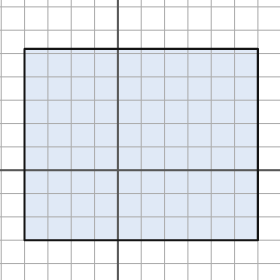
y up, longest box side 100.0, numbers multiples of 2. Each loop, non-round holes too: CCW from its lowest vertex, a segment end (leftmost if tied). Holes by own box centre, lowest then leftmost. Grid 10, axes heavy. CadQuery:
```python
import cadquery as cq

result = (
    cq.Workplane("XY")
    .moveTo(-40.0, -30.0)
    .lineTo(60.0, -30.0)
    .lineTo(60.0, 52.0)
    .lineTo(-40.0, 52.0)
    .close()
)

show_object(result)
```